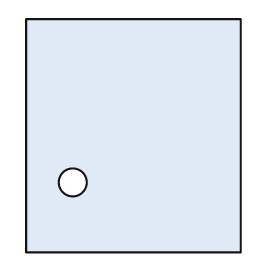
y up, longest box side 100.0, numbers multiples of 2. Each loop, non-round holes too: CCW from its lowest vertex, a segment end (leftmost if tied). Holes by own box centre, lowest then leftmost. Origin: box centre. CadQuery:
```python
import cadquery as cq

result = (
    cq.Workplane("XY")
    .moveTo(-46.0, -50.0)
    .lineTo(46.0, -50.0)
    .lineTo(46.0, 50.0)
    .lineTo(-46.0, 50.0)
    .close()
    .moveTo(-26.0, -20.0)
    .circle(6.0)
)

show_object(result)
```